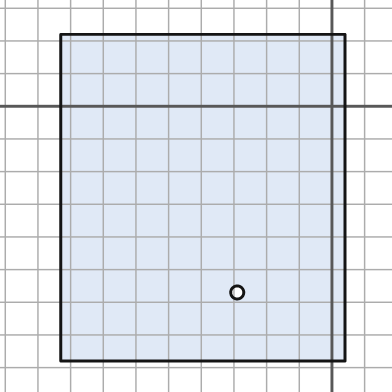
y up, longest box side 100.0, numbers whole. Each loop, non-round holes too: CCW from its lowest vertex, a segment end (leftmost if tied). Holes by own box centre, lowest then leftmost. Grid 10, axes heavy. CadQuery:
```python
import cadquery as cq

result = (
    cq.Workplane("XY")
    .moveTo(-83.0, -78.0)
    .lineTo(4.0, -78.0)
    .lineTo(4.0, 22.0)
    .lineTo(-83.0, 22.0)
    .close()
    .moveTo(-29.0, -57.0)
    .circle(2.0)
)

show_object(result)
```